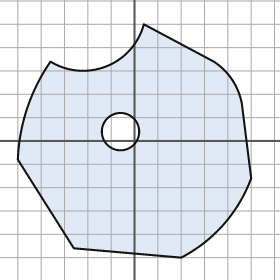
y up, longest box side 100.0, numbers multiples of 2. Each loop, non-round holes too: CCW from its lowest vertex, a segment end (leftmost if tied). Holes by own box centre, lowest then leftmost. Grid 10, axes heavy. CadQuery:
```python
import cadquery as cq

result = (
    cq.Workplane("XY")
    .moveTo(20.0, -50.0)
    .threePointArc((38.0, -36.0), (50.0, -16.0))
    .lineTo(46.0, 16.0)
    .threePointArc((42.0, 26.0), (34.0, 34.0))
    .lineTo(4.0, 50.0)
    .threePointArc((-12.0, 32.0), (-36.0, 34.0))
    .threePointArc((-46.0, 14.0), (-50.0, -8.0))
    .lineTo(-26.0, -46.0)
    .close()
    .moveTo(-6.0, 4.0)
    .circle(8.0)
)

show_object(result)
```